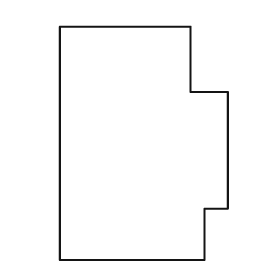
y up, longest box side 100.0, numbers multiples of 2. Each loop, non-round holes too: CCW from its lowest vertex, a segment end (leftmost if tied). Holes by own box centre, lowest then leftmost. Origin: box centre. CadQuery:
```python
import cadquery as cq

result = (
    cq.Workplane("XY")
    .moveTo(-36.0, -50.0)
    .lineTo(26.0, -50.0)
    .lineTo(26.0, -28.0)
    .lineTo(36.0, -28.0)
    .lineTo(36.0, 22.0)
    .lineTo(20.0, 22.0)
    .lineTo(20.0, 50.0)
    .lineTo(-36.0, 50.0)
    .close()
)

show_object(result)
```